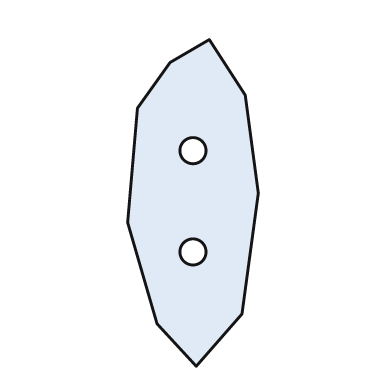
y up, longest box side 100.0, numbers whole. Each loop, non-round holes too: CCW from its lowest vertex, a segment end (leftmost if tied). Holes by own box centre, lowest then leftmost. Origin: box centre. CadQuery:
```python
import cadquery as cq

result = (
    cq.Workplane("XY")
    .moveTo(1.0, -50.0)
    .lineTo(15.0, -34.0)
    .lineTo(20.0, 3.0)
    .lineTo(16.0, 33.0)
    .lineTo(5.0, 50.0)
    .lineTo(-7.0, 43.0)
    .lineTo(-17.0, 29.0)
    .lineTo(-20.0, -6.0)
    .lineTo(-11.0, -37.0)
    .close()
    .moveTo(0.0, -15.0)
    .circle(4.0)
    .moveTo(0.0, 16.0)
    .circle(4.0)
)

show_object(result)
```